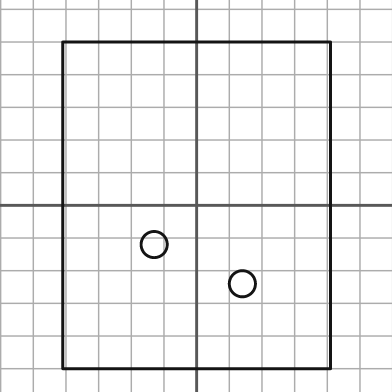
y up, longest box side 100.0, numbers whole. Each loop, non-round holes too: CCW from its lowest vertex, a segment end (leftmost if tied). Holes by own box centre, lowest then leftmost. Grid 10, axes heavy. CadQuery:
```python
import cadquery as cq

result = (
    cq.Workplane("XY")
    .moveTo(-41.0, -50.0)
    .lineTo(41.0, -50.0)
    .lineTo(41.0, 50.0)
    .lineTo(-41.0, 50.0)
    .close()
    .moveTo(14.0, -24.0)
    .circle(4.0)
    .moveTo(-13.0, -12.0)
    .circle(4.0)
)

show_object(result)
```